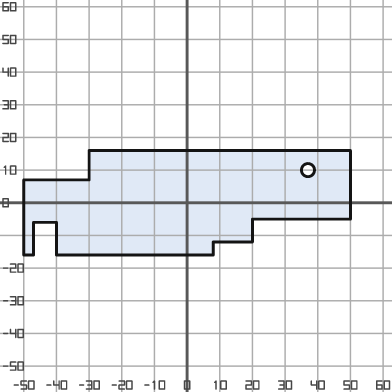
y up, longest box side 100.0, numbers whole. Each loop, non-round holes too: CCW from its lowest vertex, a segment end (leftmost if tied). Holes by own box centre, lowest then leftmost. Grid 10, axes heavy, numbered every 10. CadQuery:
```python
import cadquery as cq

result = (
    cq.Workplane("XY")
    .moveTo(-50.0, -16.0)
    .lineTo(-47.0, -16.0)
    .lineTo(-47.0, -6.0)
    .lineTo(-40.0, -6.0)
    .lineTo(-40.0, -16.0)
    .lineTo(8.0, -16.0)
    .lineTo(8.0, -12.0)
    .lineTo(20.0, -12.0)
    .lineTo(20.0, -5.0)
    .lineTo(50.0, -5.0)
    .lineTo(50.0, 16.0)
    .lineTo(-30.0, 16.0)
    .lineTo(-30.0, 7.0)
    .lineTo(-50.0, 7.0)
    .close()
    .moveTo(37.0, 10.0)
    .circle(2.0)
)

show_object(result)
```